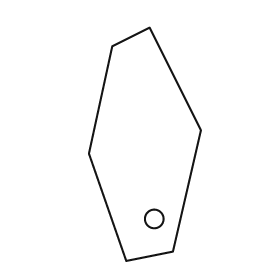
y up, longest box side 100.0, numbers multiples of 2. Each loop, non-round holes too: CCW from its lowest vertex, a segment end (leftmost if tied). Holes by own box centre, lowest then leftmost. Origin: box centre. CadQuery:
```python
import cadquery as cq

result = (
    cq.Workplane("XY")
    .moveTo(-8.0, -50.0)
    .lineTo(12.0, -46.0)
    .lineTo(24.0, 6.0)
    .lineTo(2.0, 50.0)
    .lineTo(-14.0, 42.0)
    .lineTo(-24.0, -4.0)
    .close()
    .moveTo(4.0, -32.0)
    .circle(4.0)
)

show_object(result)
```